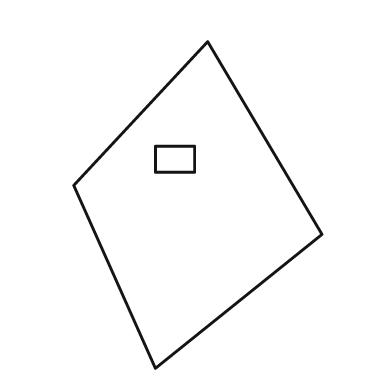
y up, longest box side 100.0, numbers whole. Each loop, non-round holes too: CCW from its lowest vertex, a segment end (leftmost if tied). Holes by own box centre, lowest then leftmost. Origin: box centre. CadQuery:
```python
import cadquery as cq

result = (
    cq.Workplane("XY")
    .moveTo(-13.0, -50.0)
    .lineTo(38.0, -9.0)
    .lineTo(3.0, 50.0)
    .lineTo(-38.0, 6.0)
    .close()
    .moveTo(-13.0, 10.0)
    .lineTo(-1.0, 10.0)
    .lineTo(-1.0, 18.0)
    .lineTo(-13.0, 18.0)
    .close()
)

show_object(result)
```